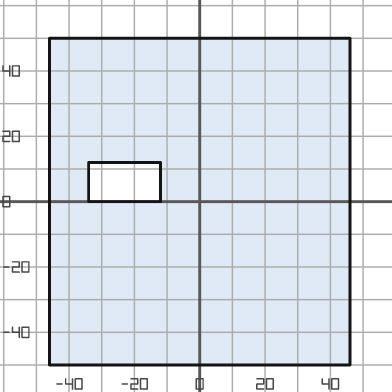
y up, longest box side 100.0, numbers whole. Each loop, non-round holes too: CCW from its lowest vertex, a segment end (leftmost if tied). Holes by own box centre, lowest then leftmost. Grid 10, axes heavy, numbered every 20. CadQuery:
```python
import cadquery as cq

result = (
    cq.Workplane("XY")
    .moveTo(-46.0, -50.0)
    .lineTo(46.0, -50.0)
    .lineTo(46.0, 50.0)
    .lineTo(-46.0, 50.0)
    .close()
    .moveTo(-34.0, 0.0)
    .lineTo(-12.0, 0.0)
    .lineTo(-12.0, 12.0)
    .lineTo(-34.0, 12.0)
    .close()
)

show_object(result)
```